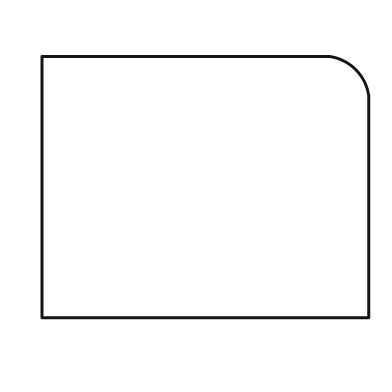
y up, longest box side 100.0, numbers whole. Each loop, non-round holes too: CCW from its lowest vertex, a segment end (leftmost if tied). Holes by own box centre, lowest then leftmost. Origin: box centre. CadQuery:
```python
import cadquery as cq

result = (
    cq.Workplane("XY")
    .moveTo(-50.0, -40.0)
    .lineTo(50.0, -40.0)
    .lineTo(50.0, 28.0)
    .threePointArc((46.0, 36.0), (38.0, 40.0))
    .lineTo(-50.0, 40.0)
    .close()
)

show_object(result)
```